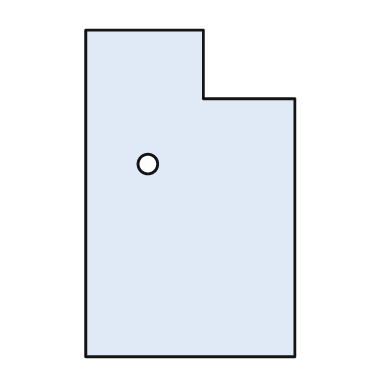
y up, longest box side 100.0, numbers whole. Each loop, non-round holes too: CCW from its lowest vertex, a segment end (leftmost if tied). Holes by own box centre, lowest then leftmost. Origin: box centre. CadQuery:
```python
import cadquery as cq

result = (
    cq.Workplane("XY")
    .moveTo(-32.0, -50.0)
    .lineTo(32.0, -50.0)
    .lineTo(32.0, 29.0)
    .lineTo(4.0, 29.0)
    .lineTo(4.0, 50.0)
    .lineTo(-32.0, 50.0)
    .close()
    .moveTo(-13.0, 9.0)
    .circle(3.0)
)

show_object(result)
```